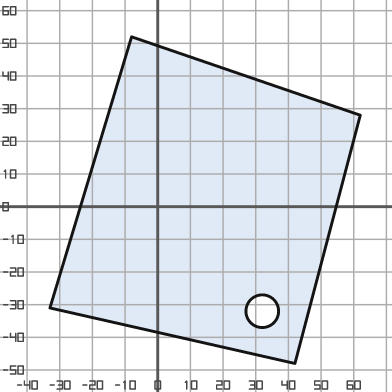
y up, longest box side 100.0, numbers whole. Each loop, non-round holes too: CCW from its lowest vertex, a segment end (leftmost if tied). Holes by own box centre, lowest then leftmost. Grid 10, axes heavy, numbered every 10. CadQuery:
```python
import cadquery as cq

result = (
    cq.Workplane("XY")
    .moveTo(42.0, -48.0)
    .lineTo(62.0, 28.0)
    .lineTo(-8.0, 52.0)
    .lineTo(-33.0, -31.0)
    .close()
    .moveTo(32.0, -32.0)
    .circle(5.0)
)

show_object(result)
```